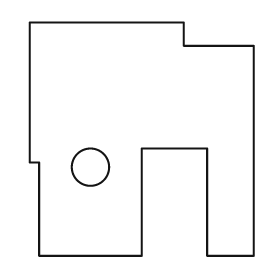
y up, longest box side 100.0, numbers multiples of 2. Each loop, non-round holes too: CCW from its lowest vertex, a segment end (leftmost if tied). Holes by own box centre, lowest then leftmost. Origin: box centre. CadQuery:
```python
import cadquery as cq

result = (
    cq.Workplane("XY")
    .moveTo(-44.0, -50.0)
    .lineTo(0.0, -50.0)
    .lineTo(0.0, -4.0)
    .lineTo(28.0, -4.0)
    .lineTo(28.0, -50.0)
    .lineTo(48.0, -50.0)
    .lineTo(48.0, 40.0)
    .lineTo(18.0, 40.0)
    .lineTo(18.0, 50.0)
    .lineTo(-48.0, 50.0)
    .lineTo(-48.0, -10.0)
    .lineTo(-44.0, -10.0)
    .close()
    .moveTo(-22.0, -12.0)
    .circle(8.0)
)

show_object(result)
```